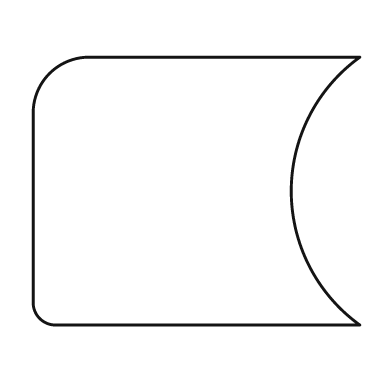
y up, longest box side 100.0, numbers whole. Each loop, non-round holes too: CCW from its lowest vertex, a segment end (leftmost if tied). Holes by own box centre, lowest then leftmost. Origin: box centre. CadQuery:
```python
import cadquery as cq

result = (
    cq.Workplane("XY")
    .moveTo(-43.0, -41.0)
    .lineTo(50.0, -41.0)
    .threePointArc((29.0, 0.0), (50.0, 41.0))
    .lineTo(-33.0, 41.0)
    .threePointArc((-45.0, 36.0), (-50.0, 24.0))
    .lineTo(-50.0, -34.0)
    .threePointArc((-48.0, -39.0), (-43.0, -41.0))
    .close()
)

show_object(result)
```